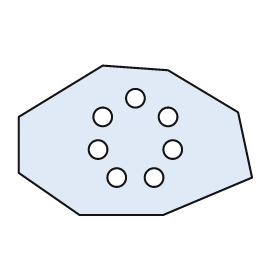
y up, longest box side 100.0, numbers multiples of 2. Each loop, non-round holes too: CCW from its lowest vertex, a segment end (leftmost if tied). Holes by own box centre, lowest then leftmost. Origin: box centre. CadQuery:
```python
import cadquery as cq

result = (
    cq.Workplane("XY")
    .moveTo(-24.0, -32.0)
    .lineTo(12.0, -32.0)
    .lineTo(50.0, -16.0)
    .lineTo(44.0, 12.0)
    .lineTo(14.0, 30.0)
    .lineTo(-14.0, 32.0)
    .lineTo(-50.0, 10.0)
    .lineTo(-50.0, -14.0)
    .close()
    .moveTo(-8.0, -16.0)
    .circle(4.0)
    .moveTo(8.0, -16.0)
    .circle(4.0)
    .moveTo(-16.0, -4.0)
    .circle(4.0)
    .moveTo(16.0, -4.0)
    .circle(4.0)
    .moveTo(-14.0, 10.0)
    .circle(4.0)
    .moveTo(14.0, 10.0)
    .circle(4.0)
    .moveTo(0.0, 18.0)
    .circle(4.0)
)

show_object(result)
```